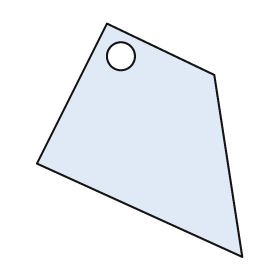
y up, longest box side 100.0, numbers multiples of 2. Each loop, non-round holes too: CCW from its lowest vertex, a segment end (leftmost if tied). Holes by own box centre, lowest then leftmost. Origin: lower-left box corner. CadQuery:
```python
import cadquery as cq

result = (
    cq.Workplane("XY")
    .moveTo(88.0, 0.0)
    .lineTo(76.0, 78.0)
    .lineTo(30.0, 100.0)
    .lineTo(0.0, 40.0)
    .close()
    .moveTo(36.0, 86.0)
    .circle(6.0)
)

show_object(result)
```